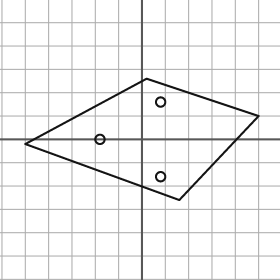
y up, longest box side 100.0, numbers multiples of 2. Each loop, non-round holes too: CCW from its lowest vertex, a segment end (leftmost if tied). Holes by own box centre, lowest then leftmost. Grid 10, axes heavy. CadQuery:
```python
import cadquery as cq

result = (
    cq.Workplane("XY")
    .moveTo(16.0, -26.0)
    .lineTo(50.0, 10.0)
    .lineTo(2.0, 26.0)
    .lineTo(-50.0, -2.0)
    .close()
    .moveTo(8.0, -16.0)
    .circle(2.0)
    .moveTo(-18.0, 0.0)
    .circle(2.0)
    .moveTo(8.0, 16.0)
    .circle(2.0)
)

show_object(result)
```